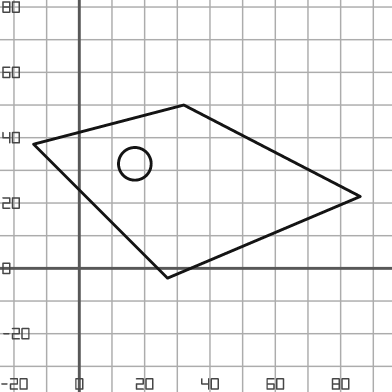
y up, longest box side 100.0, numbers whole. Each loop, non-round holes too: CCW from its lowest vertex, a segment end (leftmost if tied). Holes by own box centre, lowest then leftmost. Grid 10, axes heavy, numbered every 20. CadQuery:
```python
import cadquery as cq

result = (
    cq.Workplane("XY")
    .moveTo(27.0, -3.0)
    .lineTo(86.0, 22.0)
    .lineTo(32.0, 50.0)
    .lineTo(-14.0, 38.0)
    .close()
    .moveTo(17.0, 32.0)
    .circle(5.0)
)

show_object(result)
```